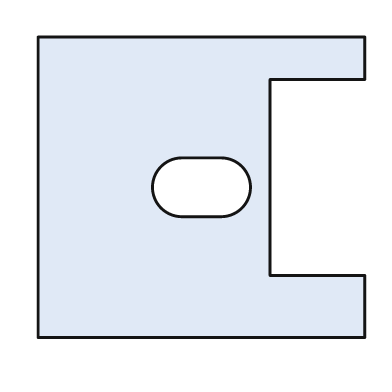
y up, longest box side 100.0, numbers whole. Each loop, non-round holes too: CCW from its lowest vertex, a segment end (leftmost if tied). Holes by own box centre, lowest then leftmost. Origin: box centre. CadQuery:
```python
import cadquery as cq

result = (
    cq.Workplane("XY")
    .moveTo(-50.0, -46.0)
    .lineTo(50.0, -46.0)
    .lineTo(50.0, -27.0)
    .lineTo(21.0, -27.0)
    .lineTo(21.0, 33.0)
    .lineTo(50.0, 33.0)
    .lineTo(50.0, 46.0)
    .lineTo(-50.0, 46.0)
    .close()
    .moveTo(-6.0, -9.0)
    .lineTo(6.0, -9.0)
    .threePointArc((15.0, 0.0), (6.0, 9.0))
    .lineTo(-6.0, 9.0)
    .threePointArc((-15.0, 0.0), (-6.0, -9.0))
    .close()
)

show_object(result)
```